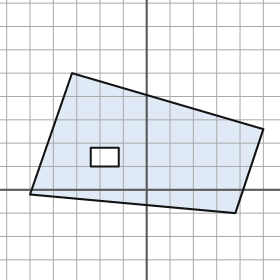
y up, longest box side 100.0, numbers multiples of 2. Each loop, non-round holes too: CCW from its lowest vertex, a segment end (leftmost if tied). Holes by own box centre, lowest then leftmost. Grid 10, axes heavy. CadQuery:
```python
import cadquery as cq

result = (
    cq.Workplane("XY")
    .moveTo(38.0, -10.0)
    .lineTo(50.0, 26.0)
    .lineTo(-32.0, 50.0)
    .lineTo(-50.0, -2.0)
    .close()
    .moveTo(-24.0, 10.0)
    .lineTo(-12.0, 10.0)
    .lineTo(-12.0, 18.0)
    .lineTo(-24.0, 18.0)
    .close()
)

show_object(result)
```